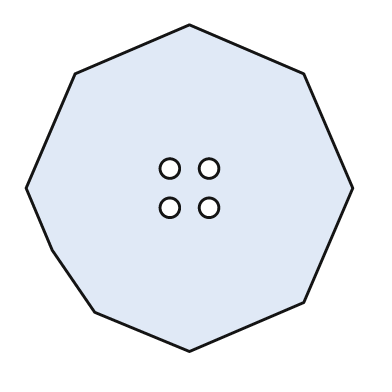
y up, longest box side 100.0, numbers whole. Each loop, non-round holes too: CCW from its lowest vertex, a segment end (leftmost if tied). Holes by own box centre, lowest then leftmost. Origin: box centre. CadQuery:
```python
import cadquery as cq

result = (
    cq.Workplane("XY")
    .moveTo(0.0, -50.0)
    .lineTo(35.0, -35.0)
    .lineTo(50.0, 0.0)
    .lineTo(35.0, 35.0)
    .lineTo(0.0, 50.0)
    .lineTo(-35.0, 35.0)
    .lineTo(-50.0, 0.0)
    .lineTo(-42.0, -19.0)
    .lineTo(-29.0, -38.0)
    .close()
    .moveTo(-6.0, -6.0)
    .circle(3.0)
    .moveTo(6.0, -6.0)
    .circle(3.0)
    .moveTo(-6.0, 6.0)
    .circle(3.0)
    .moveTo(6.0, 6.0)
    .circle(3.0)
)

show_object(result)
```